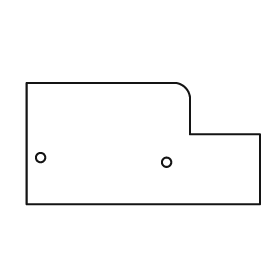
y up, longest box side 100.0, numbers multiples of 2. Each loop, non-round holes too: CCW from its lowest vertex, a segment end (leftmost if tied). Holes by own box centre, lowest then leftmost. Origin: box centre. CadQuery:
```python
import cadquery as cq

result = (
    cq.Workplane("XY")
    .moveTo(-50.0, -26.0)
    .lineTo(50.0, -26.0)
    .lineTo(50.0, 4.0)
    .lineTo(20.0, 4.0)
    .lineTo(20.0, 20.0)
    .threePointArc((18.0, 24.0), (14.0, 26.0))
    .lineTo(-50.0, 26.0)
    .close()
    .moveTo(10.0, -8.0)
    .circle(2.0)
    .moveTo(-44.0, -6.0)
    .circle(2.0)
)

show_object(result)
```